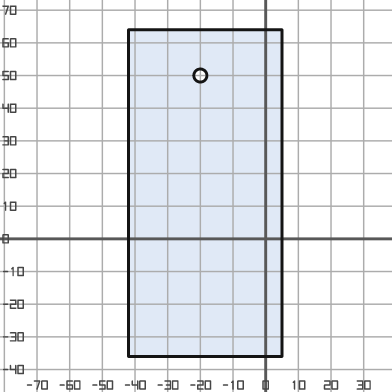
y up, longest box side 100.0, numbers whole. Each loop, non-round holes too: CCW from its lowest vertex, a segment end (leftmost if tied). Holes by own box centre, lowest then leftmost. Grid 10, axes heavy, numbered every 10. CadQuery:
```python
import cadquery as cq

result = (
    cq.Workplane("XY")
    .moveTo(-42.0, -36.0)
    .lineTo(5.0, -36.0)
    .lineTo(5.0, 64.0)
    .lineTo(-42.0, 64.0)
    .close()
    .moveTo(-20.0, 50.0)
    .circle(2.0)
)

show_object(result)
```